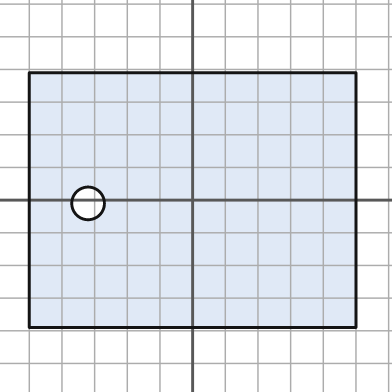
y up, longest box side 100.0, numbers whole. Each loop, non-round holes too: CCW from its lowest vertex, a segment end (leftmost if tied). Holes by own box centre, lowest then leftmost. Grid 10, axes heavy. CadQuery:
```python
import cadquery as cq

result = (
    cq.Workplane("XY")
    .moveTo(-50.0, -39.0)
    .lineTo(50.0, -39.0)
    .lineTo(50.0, 39.0)
    .lineTo(-50.0, 39.0)
    .close()
    .moveTo(-32.0, -1.0)
    .circle(5.0)
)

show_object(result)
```